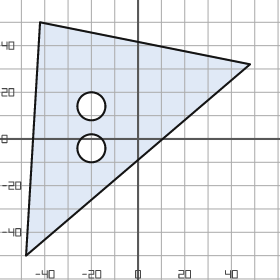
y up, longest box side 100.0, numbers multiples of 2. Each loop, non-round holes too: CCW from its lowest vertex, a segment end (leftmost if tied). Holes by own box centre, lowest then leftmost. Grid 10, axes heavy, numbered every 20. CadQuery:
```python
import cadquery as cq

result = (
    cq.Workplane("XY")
    .moveTo(-48.0, -50.0)
    .lineTo(48.0, 32.0)
    .lineTo(-42.0, 50.0)
    .close()
    .moveTo(-20.0, -4.0)
    .circle(6.0)
    .moveTo(-20.0, 14.0)
    .circle(6.0)
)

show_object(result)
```